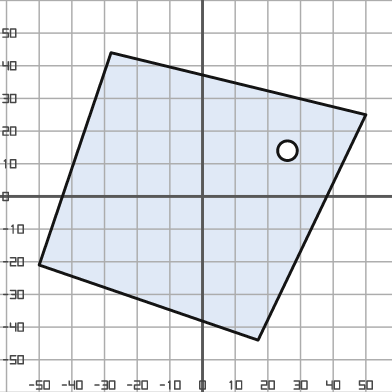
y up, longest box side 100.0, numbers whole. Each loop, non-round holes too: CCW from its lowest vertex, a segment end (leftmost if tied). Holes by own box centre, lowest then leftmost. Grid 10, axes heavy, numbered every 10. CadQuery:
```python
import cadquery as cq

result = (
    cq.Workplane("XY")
    .moveTo(17.0, -44.0)
    .lineTo(50.0, 25.0)
    .lineTo(-28.0, 44.0)
    .lineTo(-50.0, -21.0)
    .close()
    .moveTo(26.0, 14.0)
    .circle(3.0)
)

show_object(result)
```